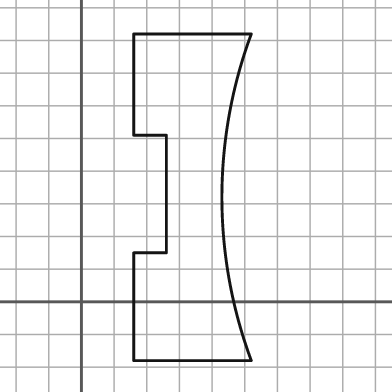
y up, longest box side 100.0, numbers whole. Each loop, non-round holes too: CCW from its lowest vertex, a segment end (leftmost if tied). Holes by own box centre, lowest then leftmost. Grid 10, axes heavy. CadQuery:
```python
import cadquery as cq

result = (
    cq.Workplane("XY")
    .moveTo(16.0, -18.0)
    .lineTo(52.0, -18.0)
    .threePointArc((43.0, 32.0), (52.0, 82.0))
    .lineTo(16.0, 82.0)
    .lineTo(16.0, 51.0)
    .lineTo(26.0, 51.0)
    .lineTo(26.0, 15.0)
    .lineTo(16.0, 15.0)
    .close()
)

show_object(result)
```